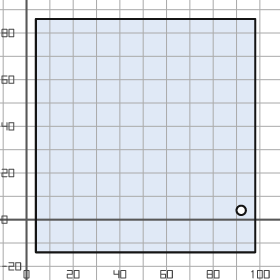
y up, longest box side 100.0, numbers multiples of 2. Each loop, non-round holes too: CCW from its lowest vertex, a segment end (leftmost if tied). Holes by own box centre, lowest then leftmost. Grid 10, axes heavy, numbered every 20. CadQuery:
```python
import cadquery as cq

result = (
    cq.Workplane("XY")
    .moveTo(4.0, -14.0)
    .lineTo(98.0, -14.0)
    .lineTo(98.0, 86.0)
    .lineTo(4.0, 86.0)
    .close()
    .moveTo(92.0, 4.0)
    .circle(2.0)
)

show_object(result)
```